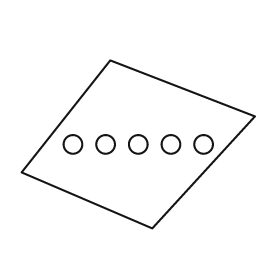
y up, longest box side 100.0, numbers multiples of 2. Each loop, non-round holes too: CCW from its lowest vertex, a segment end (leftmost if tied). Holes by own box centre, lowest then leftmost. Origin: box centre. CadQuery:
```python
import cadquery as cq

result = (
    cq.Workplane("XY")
    .moveTo(6.0, -36.0)
    .lineTo(50.0, 12.0)
    .lineTo(-12.0, 36.0)
    .lineTo(-50.0, -12.0)
    .close()
    .moveTo(-28.0, 0.0)
    .circle(4.0)
    .moveTo(-14.0, 0.0)
    .circle(4.0)
    .moveTo(0.0, 0.0)
    .circle(4.0)
    .moveTo(14.0, 0.0)
    .circle(4.0)
    .moveTo(28.0, 0.0)
    .circle(4.0)
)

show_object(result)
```